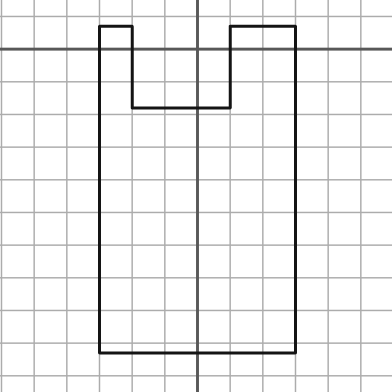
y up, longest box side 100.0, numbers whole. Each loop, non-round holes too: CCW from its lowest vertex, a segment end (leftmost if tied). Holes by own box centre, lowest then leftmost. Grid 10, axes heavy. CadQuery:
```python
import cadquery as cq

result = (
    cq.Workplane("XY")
    .moveTo(-30.0, -93.0)
    .lineTo(30.0, -93.0)
    .lineTo(30.0, 7.0)
    .lineTo(10.0, 7.0)
    .lineTo(10.0, -18.0)
    .lineTo(-20.0, -18.0)
    .lineTo(-20.0, 7.0)
    .lineTo(-30.0, 7.0)
    .close()
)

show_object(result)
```